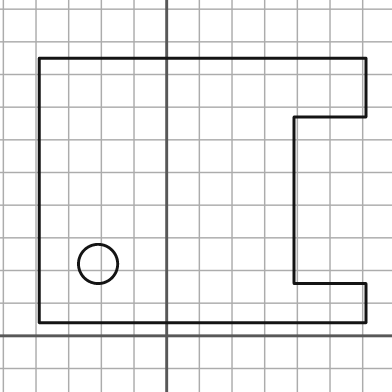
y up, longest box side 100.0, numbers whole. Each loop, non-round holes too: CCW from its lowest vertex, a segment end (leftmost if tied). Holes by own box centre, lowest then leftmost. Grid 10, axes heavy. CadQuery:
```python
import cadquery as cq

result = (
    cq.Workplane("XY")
    .moveTo(-39.0, 4.0)
    .lineTo(61.0, 4.0)
    .lineTo(61.0, 16.0)
    .lineTo(39.0, 16.0)
    .lineTo(39.0, 67.0)
    .lineTo(61.0, 67.0)
    .lineTo(61.0, 85.0)
    .lineTo(-39.0, 85.0)
    .close()
    .moveTo(-21.0, 22.0)
    .circle(6.0)
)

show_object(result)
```